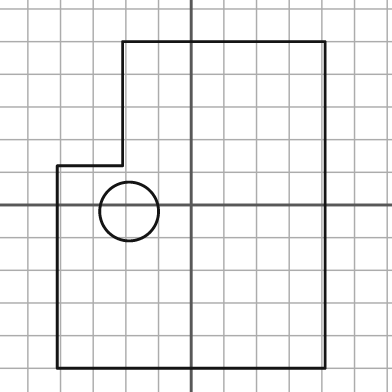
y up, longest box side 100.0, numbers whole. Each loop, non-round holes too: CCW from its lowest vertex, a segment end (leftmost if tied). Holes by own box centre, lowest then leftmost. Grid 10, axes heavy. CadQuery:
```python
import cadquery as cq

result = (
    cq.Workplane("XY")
    .moveTo(-41.0, -50.0)
    .lineTo(41.0, -50.0)
    .lineTo(41.0, 50.0)
    .lineTo(-21.0, 50.0)
    .lineTo(-21.0, 12.0)
    .lineTo(-41.0, 12.0)
    .close()
    .moveTo(-19.0, -2.0)
    .circle(9.0)
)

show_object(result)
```